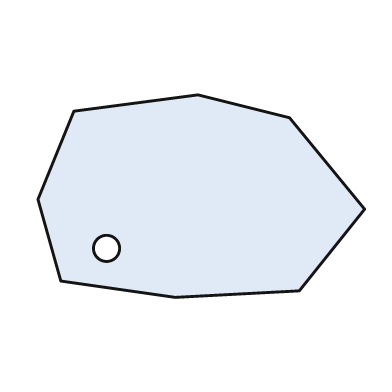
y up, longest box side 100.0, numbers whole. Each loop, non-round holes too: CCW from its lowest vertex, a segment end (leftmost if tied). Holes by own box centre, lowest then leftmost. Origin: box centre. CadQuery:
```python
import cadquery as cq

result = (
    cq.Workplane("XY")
    .moveTo(-8.0, -31.0)
    .lineTo(30.0, -29.0)
    .lineTo(50.0, -4.0)
    .lineTo(27.0, 24.0)
    .lineTo(-1.0, 31.0)
    .lineTo(-39.0, 26.0)
    .lineTo(-50.0, -1.0)
    .lineTo(-43.0, -26.0)
    .close()
    .moveTo(-29.0, -16.0)
    .circle(4.0)
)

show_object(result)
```